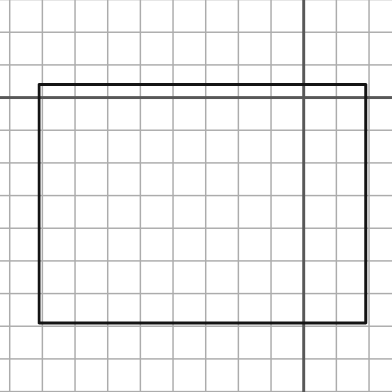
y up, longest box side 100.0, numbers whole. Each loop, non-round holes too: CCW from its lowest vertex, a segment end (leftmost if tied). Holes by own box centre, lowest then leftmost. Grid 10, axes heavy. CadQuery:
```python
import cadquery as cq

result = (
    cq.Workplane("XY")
    .moveTo(-81.0, -69.0)
    .lineTo(19.0, -69.0)
    .lineTo(19.0, 4.0)
    .lineTo(-81.0, 4.0)
    .close()
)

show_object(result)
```